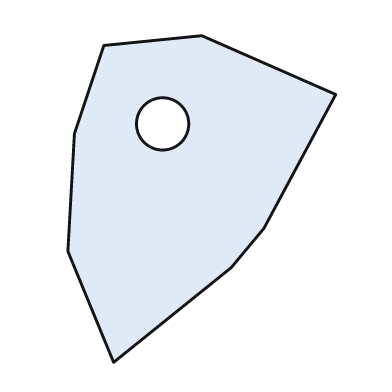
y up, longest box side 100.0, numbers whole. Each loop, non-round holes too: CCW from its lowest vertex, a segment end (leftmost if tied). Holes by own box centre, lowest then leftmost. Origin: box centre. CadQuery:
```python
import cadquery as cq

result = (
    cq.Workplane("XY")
    .moveTo(-27.0, -50.0)
    .lineTo(9.0, -21.0)
    .lineTo(19.0, -9.0)
    .lineTo(41.0, 32.0)
    .lineTo(0.0, 50.0)
    .lineTo(-30.0, 47.0)
    .lineTo(-39.0, 20.0)
    .lineTo(-41.0, -16.0)
    .close()
    .moveTo(-12.0, 23.0)
    .circle(8.0)
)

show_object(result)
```